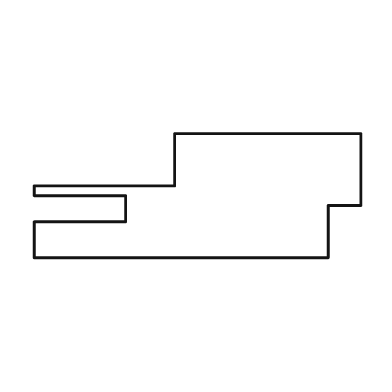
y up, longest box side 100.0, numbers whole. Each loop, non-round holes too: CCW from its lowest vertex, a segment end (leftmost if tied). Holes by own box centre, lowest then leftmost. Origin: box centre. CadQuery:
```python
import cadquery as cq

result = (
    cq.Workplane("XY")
    .moveTo(-50.0, -19.0)
    .lineTo(40.0, -19.0)
    .lineTo(40.0, -3.0)
    .lineTo(50.0, -3.0)
    .lineTo(50.0, 19.0)
    .lineTo(-7.0, 19.0)
    .lineTo(-7.0, 3.0)
    .lineTo(-50.0, 3.0)
    .lineTo(-50.0, 0.0)
    .lineTo(-22.0, 0.0)
    .lineTo(-22.0, -8.0)
    .lineTo(-50.0, -8.0)
    .close()
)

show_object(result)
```